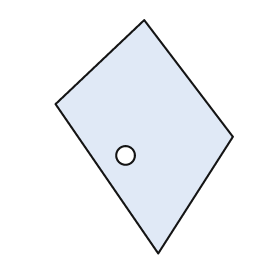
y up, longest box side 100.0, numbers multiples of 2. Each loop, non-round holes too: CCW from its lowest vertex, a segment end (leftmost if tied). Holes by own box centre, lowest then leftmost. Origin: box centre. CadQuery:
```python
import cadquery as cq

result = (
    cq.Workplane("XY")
    .moveTo(6.0, -50.0)
    .lineTo(38.0, 0.0)
    .lineTo(0.0, 50.0)
    .lineTo(-38.0, 14.0)
    .close()
    .moveTo(-8.0, -8.0)
    .circle(4.0)
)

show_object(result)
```